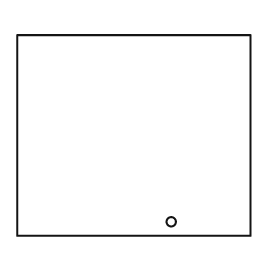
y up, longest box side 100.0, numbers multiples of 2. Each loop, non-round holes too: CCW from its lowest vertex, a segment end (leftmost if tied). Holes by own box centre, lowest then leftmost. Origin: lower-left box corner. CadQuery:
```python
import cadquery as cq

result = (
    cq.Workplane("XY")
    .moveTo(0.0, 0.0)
    .lineTo(100.0, 0.0)
    .lineTo(100.0, 86.0)
    .lineTo(0.0, 86.0)
    .close()
    .moveTo(66.0, 6.0)
    .circle(2.0)
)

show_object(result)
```